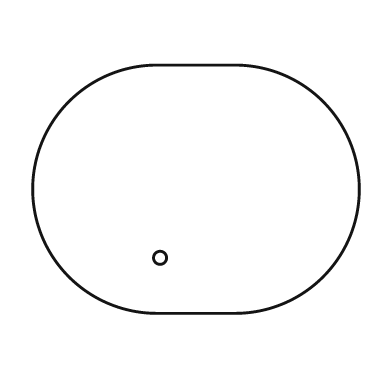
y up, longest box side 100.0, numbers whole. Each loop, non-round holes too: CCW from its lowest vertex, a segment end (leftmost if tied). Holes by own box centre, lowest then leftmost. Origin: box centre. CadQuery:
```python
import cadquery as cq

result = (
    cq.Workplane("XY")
    .moveTo(-12.0, -38.0)
    .lineTo(12.0, -38.0)
    .threePointArc((50.0, 0.0), (12.0, 38.0))
    .lineTo(-12.0, 38.0)
    .threePointArc((-50.0, 0.0), (-12.0, -38.0))
    .close()
    .moveTo(-11.0, -21.0)
    .circle(2.0)
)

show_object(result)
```